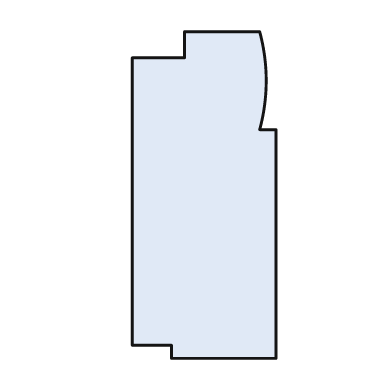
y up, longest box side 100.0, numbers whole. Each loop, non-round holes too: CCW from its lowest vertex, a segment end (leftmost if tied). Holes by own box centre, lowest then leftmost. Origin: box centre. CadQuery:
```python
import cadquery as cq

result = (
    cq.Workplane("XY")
    .moveTo(-10.0, -50.0)
    .lineTo(22.0, -50.0)
    .lineTo(22.0, 20.0)
    .lineTo(17.0, 20.0)
    .threePointArc((19.0, 35.0), (17.0, 50.0))
    .lineTo(-6.0, 50.0)
    .lineTo(-6.0, 42.0)
    .lineTo(-22.0, 42.0)
    .lineTo(-22.0, -46.0)
    .lineTo(-10.0, -46.0)
    .close()
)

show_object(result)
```